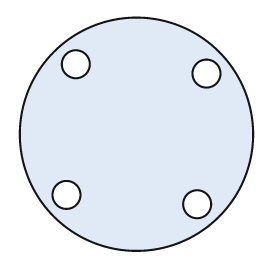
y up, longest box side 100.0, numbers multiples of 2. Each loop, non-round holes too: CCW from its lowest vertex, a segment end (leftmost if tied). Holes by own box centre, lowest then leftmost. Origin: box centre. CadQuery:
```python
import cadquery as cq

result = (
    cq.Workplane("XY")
    .moveTo(0.0, 0.0)
    .circle(50.0)
    .moveTo(26.0, -30.0)
    .circle(6.0)
    .moveTo(-30.0, -26.0)
    .circle(6.0)
    .moveTo(30.0, 26.0)
    .circle(6.0)
    .moveTo(-26.0, 30.0)
    .circle(6.0)
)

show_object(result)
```